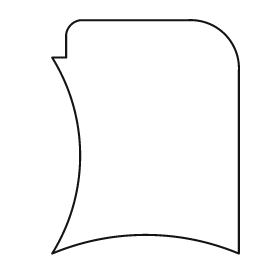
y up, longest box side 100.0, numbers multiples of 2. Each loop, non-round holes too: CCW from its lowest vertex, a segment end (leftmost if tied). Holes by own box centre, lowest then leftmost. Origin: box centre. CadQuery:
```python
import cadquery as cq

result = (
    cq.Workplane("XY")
    .moveTo(-40.0, -50.0)
    .threePointArc((0.0, -42.0), (40.0, -50.0))
    .lineTo(40.0, 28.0)
    .threePointArc((34.0, 44.0), (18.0, 50.0))
    .lineTo(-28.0, 50.0)
    .threePointArc((-32.0, 48.0), (-34.0, 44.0))
    .lineTo(-34.0, 34.0)
    .lineTo(-40.0, 34.0)
    .threePointArc((-28.0, -8.0), (-40.0, -50.0))
    .close()
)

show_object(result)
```